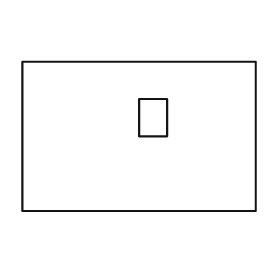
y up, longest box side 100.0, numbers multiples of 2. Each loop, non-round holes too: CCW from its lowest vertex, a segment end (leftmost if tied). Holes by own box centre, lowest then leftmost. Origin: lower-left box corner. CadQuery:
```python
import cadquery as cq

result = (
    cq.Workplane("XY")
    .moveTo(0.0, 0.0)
    .lineTo(100.0, 0.0)
    .lineTo(100.0, 64.0)
    .lineTo(0.0, 64.0)
    .close()
    .moveTo(50.0, 32.0)
    .lineTo(62.0, 32.0)
    .lineTo(62.0, 48.0)
    .lineTo(50.0, 48.0)
    .close()
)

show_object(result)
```